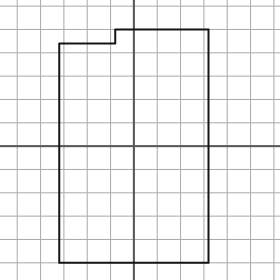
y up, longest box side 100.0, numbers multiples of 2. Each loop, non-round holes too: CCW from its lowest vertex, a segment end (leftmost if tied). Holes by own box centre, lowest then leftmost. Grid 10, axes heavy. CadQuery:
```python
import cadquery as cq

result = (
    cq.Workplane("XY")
    .moveTo(-32.0, -50.0)
    .lineTo(32.0, -50.0)
    .lineTo(32.0, 50.0)
    .lineTo(-8.0, 50.0)
    .lineTo(-8.0, 44.0)
    .lineTo(-32.0, 44.0)
    .close()
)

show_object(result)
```